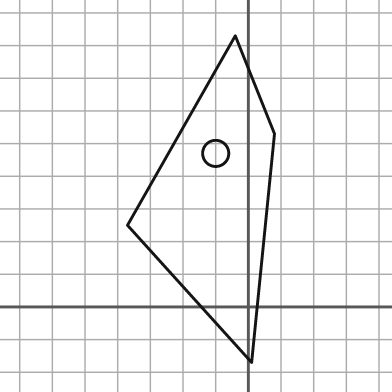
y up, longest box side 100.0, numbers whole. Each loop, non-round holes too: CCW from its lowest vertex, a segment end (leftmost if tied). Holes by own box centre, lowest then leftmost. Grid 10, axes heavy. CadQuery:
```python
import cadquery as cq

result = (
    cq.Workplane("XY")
    .moveTo(1.0, -17.0)
    .lineTo(8.0, 53.0)
    .lineTo(-4.0, 83.0)
    .lineTo(-37.0, 25.0)
    .close()
    .moveTo(-10.0, 47.0)
    .circle(4.0)
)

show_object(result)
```